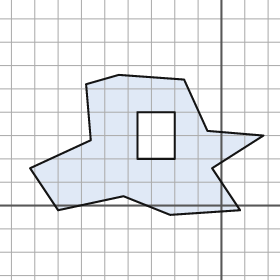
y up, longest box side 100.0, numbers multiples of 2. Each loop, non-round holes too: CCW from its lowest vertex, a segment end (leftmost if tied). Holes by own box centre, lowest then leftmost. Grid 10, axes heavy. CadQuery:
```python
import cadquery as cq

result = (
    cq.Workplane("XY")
    .moveTo(-22.0, -4.0)
    .lineTo(8.0, -2.0)
    .lineTo(-4.0, 16.0)
    .lineTo(18.0, 30.0)
    .lineTo(-6.0, 32.0)
    .lineTo(-16.0, 54.0)
    .lineTo(-44.0, 56.0)
    .lineTo(-58.0, 52.0)
    .lineTo(-56.0, 28.0)
    .lineTo(-82.0, 16.0)
    .lineTo(-70.0, -2.0)
    .lineTo(-42.0, 4.0)
    .close()
    .moveTo(-36.0, 20.0)
    .lineTo(-20.0, 20.0)
    .lineTo(-20.0, 40.0)
    .lineTo(-36.0, 40.0)
    .close()
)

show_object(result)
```